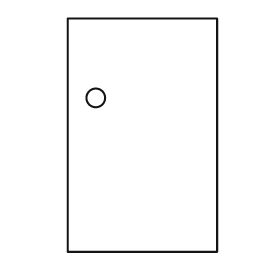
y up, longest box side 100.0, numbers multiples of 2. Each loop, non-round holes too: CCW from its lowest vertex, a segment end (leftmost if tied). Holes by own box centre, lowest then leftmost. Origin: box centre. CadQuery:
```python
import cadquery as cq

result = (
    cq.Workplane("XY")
    .moveTo(-32.0, -50.0)
    .lineTo(32.0, -50.0)
    .lineTo(32.0, 50.0)
    .lineTo(-32.0, 50.0)
    .close()
    .moveTo(-20.0, 16.0)
    .circle(4.0)
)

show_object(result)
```